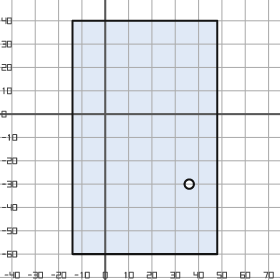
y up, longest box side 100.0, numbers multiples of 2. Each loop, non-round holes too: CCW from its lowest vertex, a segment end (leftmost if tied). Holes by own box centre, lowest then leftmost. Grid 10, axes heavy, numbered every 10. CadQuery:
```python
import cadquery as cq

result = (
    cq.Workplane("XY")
    .moveTo(-14.0, -60.0)
    .lineTo(48.0, -60.0)
    .lineTo(48.0, 40.0)
    .lineTo(-14.0, 40.0)
    .close()
    .moveTo(36.0, -30.0)
    .circle(2.0)
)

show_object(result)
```